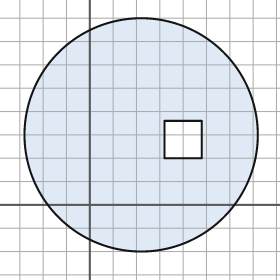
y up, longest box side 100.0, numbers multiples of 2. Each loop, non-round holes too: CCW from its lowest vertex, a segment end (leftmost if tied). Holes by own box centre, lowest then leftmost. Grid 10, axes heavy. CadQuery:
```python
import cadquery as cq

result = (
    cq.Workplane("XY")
    .moveTo(22.0, 30.0)
    .circle(50.0)
    .moveTo(32.0, 20.0)
    .lineTo(48.0, 20.0)
    .lineTo(48.0, 36.0)
    .lineTo(32.0, 36.0)
    .close()
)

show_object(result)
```